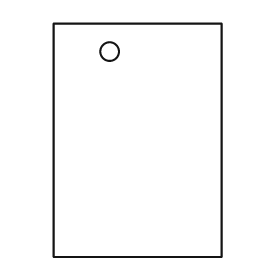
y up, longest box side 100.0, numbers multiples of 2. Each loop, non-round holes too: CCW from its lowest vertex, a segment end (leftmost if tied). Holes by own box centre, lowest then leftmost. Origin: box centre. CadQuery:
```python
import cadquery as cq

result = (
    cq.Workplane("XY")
    .moveTo(-36.0, -50.0)
    .lineTo(36.0, -50.0)
    .lineTo(36.0, 50.0)
    .lineTo(-36.0, 50.0)
    .close()
    .moveTo(-12.0, 38.0)
    .circle(4.0)
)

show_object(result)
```